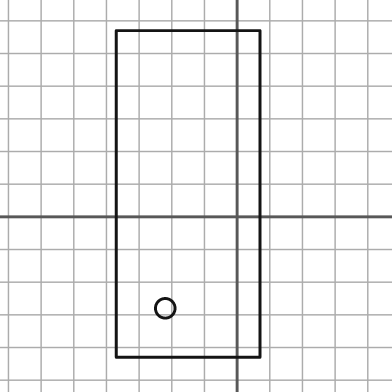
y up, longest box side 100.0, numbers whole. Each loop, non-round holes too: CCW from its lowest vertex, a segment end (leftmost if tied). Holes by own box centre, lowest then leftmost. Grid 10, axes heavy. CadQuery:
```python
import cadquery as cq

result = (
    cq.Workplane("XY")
    .moveTo(-37.0, -43.0)
    .lineTo(7.0, -43.0)
    .lineTo(7.0, 57.0)
    .lineTo(-37.0, 57.0)
    .close()
    .moveTo(-22.0, -28.0)
    .circle(3.0)
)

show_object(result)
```